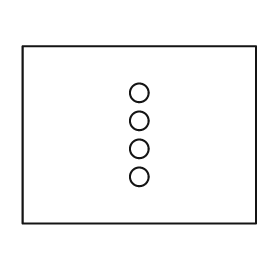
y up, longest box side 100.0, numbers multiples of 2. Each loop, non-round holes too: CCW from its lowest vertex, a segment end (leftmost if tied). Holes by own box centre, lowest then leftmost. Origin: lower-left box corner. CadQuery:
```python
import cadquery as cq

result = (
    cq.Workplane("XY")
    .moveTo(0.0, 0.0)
    .lineTo(100.0, 0.0)
    .lineTo(100.0, 76.0)
    .lineTo(0.0, 76.0)
    .close()
    .moveTo(50.0, 20.0)
    .circle(4.0)
    .moveTo(50.0, 32.0)
    .circle(4.0)
    .moveTo(50.0, 44.0)
    .circle(4.0)
    .moveTo(50.0, 56.0)
    .circle(4.0)
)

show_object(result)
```